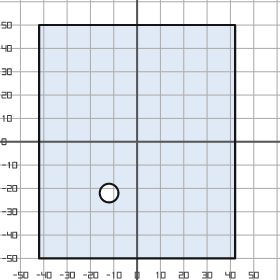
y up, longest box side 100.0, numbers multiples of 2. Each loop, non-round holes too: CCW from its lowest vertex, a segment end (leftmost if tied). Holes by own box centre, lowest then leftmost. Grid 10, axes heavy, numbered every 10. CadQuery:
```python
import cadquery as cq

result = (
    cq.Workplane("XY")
    .moveTo(-42.0, -50.0)
    .lineTo(42.0, -50.0)
    .lineTo(42.0, 50.0)
    .lineTo(-42.0, 50.0)
    .close()
    .moveTo(-12.0, -22.0)
    .circle(4.0)
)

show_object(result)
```